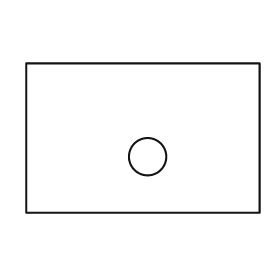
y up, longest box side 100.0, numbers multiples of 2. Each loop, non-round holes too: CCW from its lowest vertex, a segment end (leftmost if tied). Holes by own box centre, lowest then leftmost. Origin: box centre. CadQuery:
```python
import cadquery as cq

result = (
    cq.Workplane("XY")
    .moveTo(-50.0, -32.0)
    .lineTo(50.0, -32.0)
    .lineTo(50.0, 32.0)
    .lineTo(-50.0, 32.0)
    .close()
    .moveTo(2.0, -8.0)
    .circle(8.0)
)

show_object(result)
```